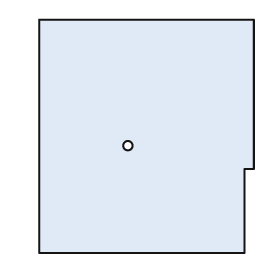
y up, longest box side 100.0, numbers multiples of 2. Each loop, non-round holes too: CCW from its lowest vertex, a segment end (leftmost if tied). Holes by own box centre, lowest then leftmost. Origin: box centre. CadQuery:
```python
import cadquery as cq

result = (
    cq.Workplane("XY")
    .moveTo(-46.0, -50.0)
    .lineTo(42.0, -50.0)
    .lineTo(42.0, -14.0)
    .lineTo(46.0, -14.0)
    .lineTo(46.0, 50.0)
    .lineTo(-46.0, 50.0)
    .close()
    .moveTo(-8.0, -4.0)
    .circle(2.0)
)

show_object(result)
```